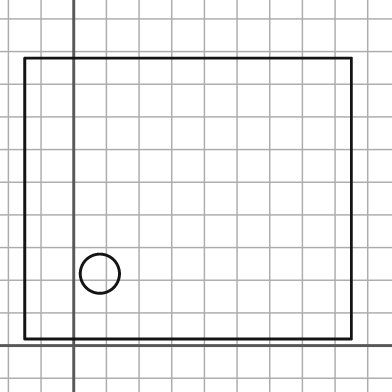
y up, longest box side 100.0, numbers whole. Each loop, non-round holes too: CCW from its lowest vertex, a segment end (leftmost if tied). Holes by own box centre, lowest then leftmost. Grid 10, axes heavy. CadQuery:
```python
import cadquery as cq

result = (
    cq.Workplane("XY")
    .moveTo(-15.0, 2.0)
    .lineTo(85.0, 2.0)
    .lineTo(85.0, 88.0)
    .lineTo(-15.0, 88.0)
    .close()
    .moveTo(8.0, 22.0)
    .circle(6.0)
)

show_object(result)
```